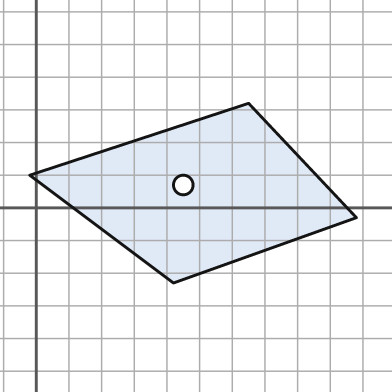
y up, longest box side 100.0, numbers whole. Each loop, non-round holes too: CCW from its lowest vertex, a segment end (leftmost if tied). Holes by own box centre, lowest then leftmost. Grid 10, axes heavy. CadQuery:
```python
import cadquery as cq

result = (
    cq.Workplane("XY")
    .moveTo(42.0, -23.0)
    .lineTo(98.0, -3.0)
    .lineTo(65.0, 32.0)
    .lineTo(-2.0, 10.0)
    .close()
    .moveTo(45.0, 7.0)
    .circle(3.0)
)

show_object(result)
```